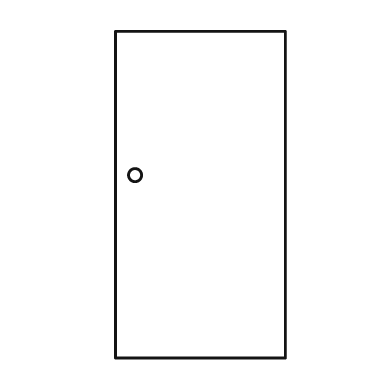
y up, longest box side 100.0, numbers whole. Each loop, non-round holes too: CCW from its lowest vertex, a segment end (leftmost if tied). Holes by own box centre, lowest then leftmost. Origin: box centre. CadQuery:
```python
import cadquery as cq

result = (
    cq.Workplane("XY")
    .moveTo(-26.0, -50.0)
    .lineTo(26.0, -50.0)
    .lineTo(26.0, 50.0)
    .lineTo(-26.0, 50.0)
    .close()
    .moveTo(-20.0, 6.0)
    .circle(2.0)
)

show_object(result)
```